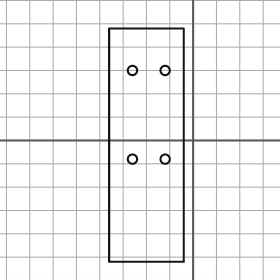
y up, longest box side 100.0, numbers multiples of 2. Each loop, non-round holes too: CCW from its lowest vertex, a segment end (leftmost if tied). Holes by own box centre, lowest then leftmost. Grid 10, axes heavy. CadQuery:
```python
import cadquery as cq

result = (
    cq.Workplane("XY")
    .moveTo(-36.0, -52.0)
    .lineTo(-4.0, -52.0)
    .lineTo(-4.0, 48.0)
    .lineTo(-36.0, 48.0)
    .close()
    .moveTo(-26.0, -8.0)
    .circle(2.0)
    .moveTo(-12.0, -8.0)
    .circle(2.0)
    .moveTo(-26.0, 30.0)
    .circle(2.0)
    .moveTo(-12.0, 30.0)
    .circle(2.0)
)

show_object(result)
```